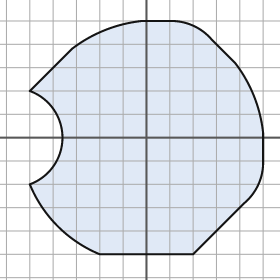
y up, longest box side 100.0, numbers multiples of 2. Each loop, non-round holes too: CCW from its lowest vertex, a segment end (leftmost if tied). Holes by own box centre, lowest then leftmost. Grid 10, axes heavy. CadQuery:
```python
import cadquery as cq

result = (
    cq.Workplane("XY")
    .moveTo(-20.0, -50.0)
    .lineTo(20.0, -50.0)
    .lineTo(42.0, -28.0)
    .threePointArc((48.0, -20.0), (50.0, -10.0))
    .lineTo(50.0, 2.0)
    .threePointArc((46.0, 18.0), (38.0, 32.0))
    .lineTo(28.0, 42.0)
    .threePointArc((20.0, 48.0), (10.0, 50.0))
    .lineTo(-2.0, 50.0)
    .threePointArc((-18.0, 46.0), (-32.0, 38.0))
    .lineTo(-50.0, 20.0)
    .threePointArc((-36.0, 0.0), (-50.0, -20.0))
    .threePointArc((-38.0, -38.0), (-20.0, -50.0))
    .close()
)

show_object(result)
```